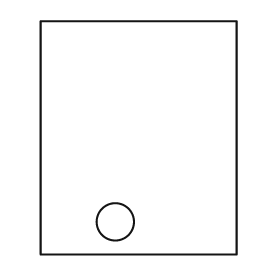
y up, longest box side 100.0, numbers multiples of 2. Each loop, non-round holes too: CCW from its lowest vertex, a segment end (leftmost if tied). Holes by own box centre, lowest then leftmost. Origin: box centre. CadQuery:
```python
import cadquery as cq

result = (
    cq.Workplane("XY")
    .moveTo(-42.0, -50.0)
    .lineTo(42.0, -50.0)
    .lineTo(42.0, 50.0)
    .lineTo(-42.0, 50.0)
    .close()
    .moveTo(-10.0, -36.0)
    .circle(8.0)
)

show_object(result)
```